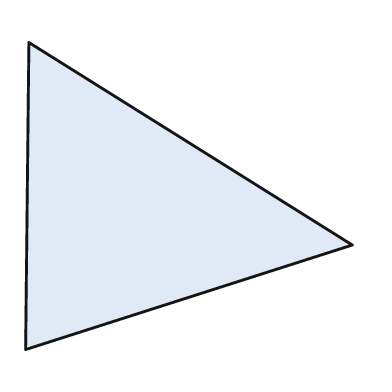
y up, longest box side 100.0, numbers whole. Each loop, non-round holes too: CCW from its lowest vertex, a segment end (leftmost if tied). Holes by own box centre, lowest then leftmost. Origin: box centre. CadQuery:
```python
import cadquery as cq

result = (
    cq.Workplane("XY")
    .moveTo(-50.0, -47.0)
    .lineTo(50.0, -15.0)
    .lineTo(-49.0, 47.0)
    .close()
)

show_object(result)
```